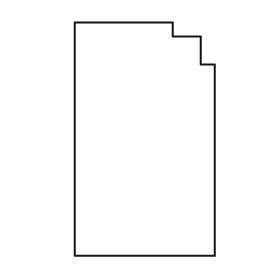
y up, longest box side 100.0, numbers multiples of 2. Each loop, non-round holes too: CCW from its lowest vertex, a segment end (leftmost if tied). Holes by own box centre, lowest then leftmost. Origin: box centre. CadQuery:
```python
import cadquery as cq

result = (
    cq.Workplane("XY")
    .moveTo(-30.0, -50.0)
    .lineTo(30.0, -50.0)
    .lineTo(30.0, 32.0)
    .lineTo(24.0, 32.0)
    .lineTo(24.0, 44.0)
    .lineTo(12.0, 44.0)
    .lineTo(12.0, 50.0)
    .lineTo(-30.0, 50.0)
    .close()
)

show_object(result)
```